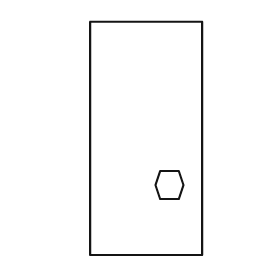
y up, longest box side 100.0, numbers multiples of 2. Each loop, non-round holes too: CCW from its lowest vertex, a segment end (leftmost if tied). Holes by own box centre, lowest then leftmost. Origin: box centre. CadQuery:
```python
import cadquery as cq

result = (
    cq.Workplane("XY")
    .moveTo(-24.0, -50.0)
    .lineTo(24.0, -50.0)
    .lineTo(24.0, 50.0)
    .lineTo(-24.0, 50.0)
    .close()
    .moveTo(6.0, -26.0)
    .lineTo(14.0, -26.0)
    .lineTo(16.0, -20.0)
    .lineTo(14.0, -14.0)
    .lineTo(6.0, -14.0)
    .lineTo(4.0, -20.0)
    .close()
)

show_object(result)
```